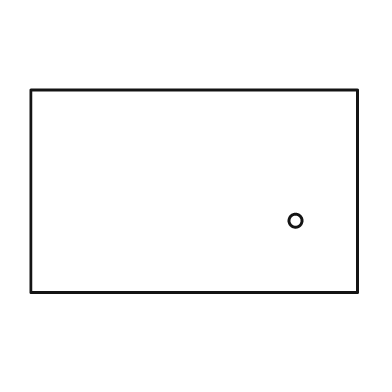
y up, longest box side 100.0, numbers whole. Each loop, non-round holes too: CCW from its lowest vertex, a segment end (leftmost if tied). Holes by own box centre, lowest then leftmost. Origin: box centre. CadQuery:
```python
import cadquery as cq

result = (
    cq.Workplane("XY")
    .moveTo(-50.0, -31.0)
    .lineTo(50.0, -31.0)
    .lineTo(50.0, 31.0)
    .lineTo(-50.0, 31.0)
    .close()
    .moveTo(31.0, -9.0)
    .circle(2.0)
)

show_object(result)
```